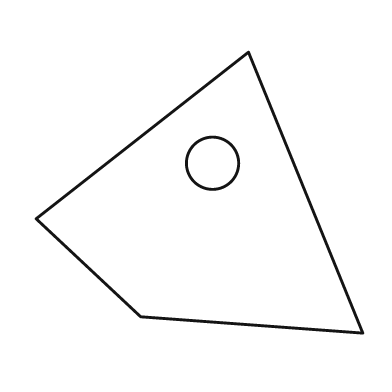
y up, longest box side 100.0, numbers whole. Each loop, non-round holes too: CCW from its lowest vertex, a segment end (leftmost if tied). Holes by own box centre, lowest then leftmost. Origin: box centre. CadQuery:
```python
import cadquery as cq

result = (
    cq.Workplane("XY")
    .moveTo(50.0, -43.0)
    .lineTo(15.0, 43.0)
    .lineTo(-50.0, -8.0)
    .lineTo(-18.0, -38.0)
    .close()
    .moveTo(4.0, 9.0)
    .circle(8.0)
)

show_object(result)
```